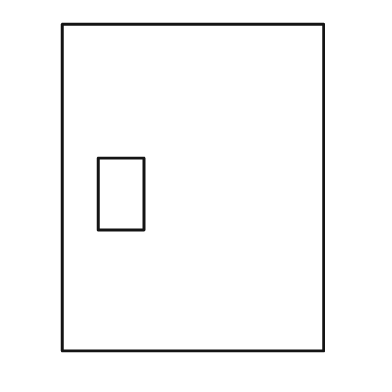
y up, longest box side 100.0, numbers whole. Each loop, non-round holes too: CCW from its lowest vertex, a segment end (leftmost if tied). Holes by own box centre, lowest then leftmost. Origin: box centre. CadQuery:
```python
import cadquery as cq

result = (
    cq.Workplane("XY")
    .moveTo(-40.0, -50.0)
    .lineTo(40.0, -50.0)
    .lineTo(40.0, 50.0)
    .lineTo(-40.0, 50.0)
    .close()
    .moveTo(-29.0, -13.0)
    .lineTo(-15.0, -13.0)
    .lineTo(-15.0, 9.0)
    .lineTo(-29.0, 9.0)
    .close()
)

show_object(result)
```